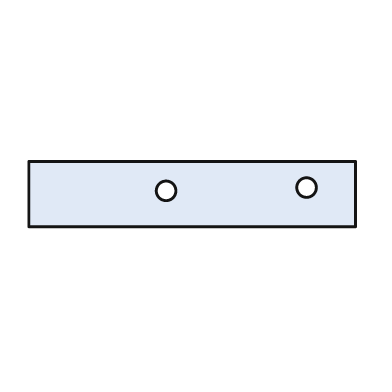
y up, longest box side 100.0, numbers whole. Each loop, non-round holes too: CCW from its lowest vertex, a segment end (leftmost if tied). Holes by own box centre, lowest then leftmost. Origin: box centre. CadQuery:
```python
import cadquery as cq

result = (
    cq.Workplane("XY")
    .moveTo(-50.0, -10.0)
    .lineTo(50.0, -10.0)
    .lineTo(50.0, 10.0)
    .lineTo(-50.0, 10.0)
    .close()
    .moveTo(-8.0, 1.0)
    .circle(3.0)
    .moveTo(35.0, 2.0)
    .circle(3.0)
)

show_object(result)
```